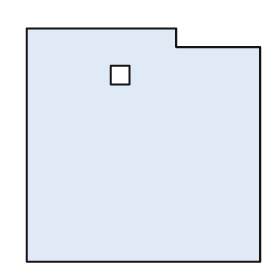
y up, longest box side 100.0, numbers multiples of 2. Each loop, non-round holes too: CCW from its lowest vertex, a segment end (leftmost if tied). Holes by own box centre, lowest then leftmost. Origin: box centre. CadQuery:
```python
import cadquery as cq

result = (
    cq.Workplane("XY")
    .moveTo(-50.0, -50.0)
    .lineTo(50.0, -50.0)
    .lineTo(50.0, 42.0)
    .lineTo(14.0, 42.0)
    .lineTo(14.0, 50.0)
    .lineTo(-50.0, 50.0)
    .close()
    .moveTo(-14.0, 26.0)
    .lineTo(-6.0, 26.0)
    .lineTo(-6.0, 34.0)
    .lineTo(-14.0, 34.0)
    .close()
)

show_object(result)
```